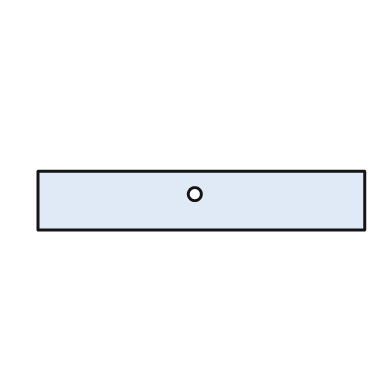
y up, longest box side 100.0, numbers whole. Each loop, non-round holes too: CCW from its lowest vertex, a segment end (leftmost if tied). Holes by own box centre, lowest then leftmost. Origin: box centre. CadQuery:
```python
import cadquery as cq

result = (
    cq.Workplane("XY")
    .moveTo(-50.0, -9.0)
    .lineTo(50.0, -9.0)
    .lineTo(50.0, 9.0)
    .lineTo(-50.0, 9.0)
    .close()
    .moveTo(-2.0, 2.0)
    .circle(2.0)
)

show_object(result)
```